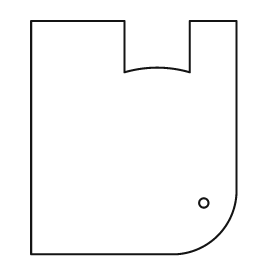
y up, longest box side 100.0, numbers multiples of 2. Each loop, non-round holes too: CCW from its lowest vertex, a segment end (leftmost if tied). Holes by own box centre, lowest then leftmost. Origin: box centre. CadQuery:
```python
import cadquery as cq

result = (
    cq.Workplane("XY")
    .moveTo(-44.0, -50.0)
    .lineTo(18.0, -50.0)
    .threePointArc((36.0, -42.0), (44.0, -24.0))
    .lineTo(44.0, 50.0)
    .lineTo(24.0, 50.0)
    .lineTo(24.0, 28.0)
    .threePointArc((10.0, 30.0), (-4.0, 28.0))
    .lineTo(-4.0, 50.0)
    .lineTo(-44.0, 50.0)
    .close()
    .moveTo(30.0, -28.0)
    .circle(2.0)
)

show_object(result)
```